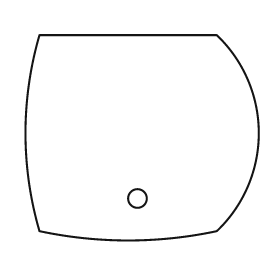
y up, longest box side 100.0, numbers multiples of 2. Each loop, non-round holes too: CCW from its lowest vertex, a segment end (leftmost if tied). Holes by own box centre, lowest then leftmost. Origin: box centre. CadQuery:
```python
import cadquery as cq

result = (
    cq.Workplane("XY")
    .moveTo(-44.0, -40.0)
    .threePointArc((-6.0, -44.0), (32.0, -40.0))
    .threePointArc((50.0, 2.0), (32.0, 44.0))
    .lineTo(-44.0, 44.0)
    .threePointArc((-50.0, 2.0), (-44.0, -40.0))
    .close()
    .moveTo(-2.0, -26.0)
    .circle(4.0)
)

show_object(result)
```